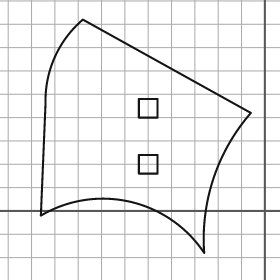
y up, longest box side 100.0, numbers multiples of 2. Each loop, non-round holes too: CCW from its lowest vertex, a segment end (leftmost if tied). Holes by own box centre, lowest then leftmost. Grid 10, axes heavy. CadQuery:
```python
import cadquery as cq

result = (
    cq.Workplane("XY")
    .moveTo(-26.0, -18.0)
    .threePointArc((-22.0, 14.0), (-6.0, 42.0))
    .lineTo(-78.0, 82.0)
    .threePointArc((-90.0, 66.0), (-94.0, 46.0))
    .lineTo(-96.0, -2.0)
    .threePointArc((-58.0, 4.0), (-26.0, -18.0))
    .close()
    .moveTo(-54.0, 16.0)
    .lineTo(-46.0, 16.0)
    .lineTo(-46.0, 24.0)
    .lineTo(-54.0, 24.0)
    .close()
    .moveTo(-54.0, 40.0)
    .lineTo(-46.0, 40.0)
    .lineTo(-46.0, 48.0)
    .lineTo(-54.0, 48.0)
    .close()
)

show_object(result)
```